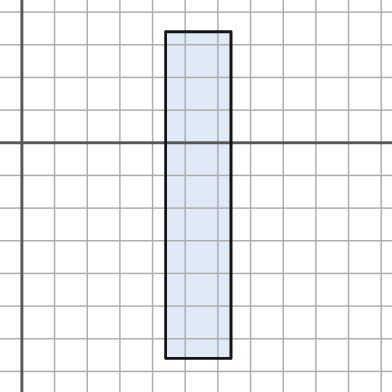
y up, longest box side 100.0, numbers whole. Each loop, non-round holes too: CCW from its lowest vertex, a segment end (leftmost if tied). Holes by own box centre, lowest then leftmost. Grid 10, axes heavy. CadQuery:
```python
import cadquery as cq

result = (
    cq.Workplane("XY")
    .moveTo(44.0, -66.0)
    .lineTo(64.0, -66.0)
    .lineTo(64.0, 34.0)
    .lineTo(44.0, 34.0)
    .close()
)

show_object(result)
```